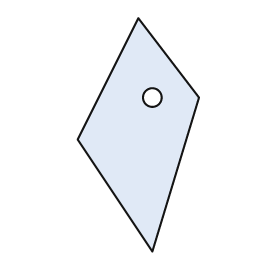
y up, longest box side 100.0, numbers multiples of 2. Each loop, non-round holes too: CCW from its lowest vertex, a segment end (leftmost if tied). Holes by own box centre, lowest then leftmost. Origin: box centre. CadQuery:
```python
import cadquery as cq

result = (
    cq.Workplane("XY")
    .moveTo(6.0, -50.0)
    .lineTo(26.0, 16.0)
    .lineTo(0.0, 50.0)
    .lineTo(-26.0, -2.0)
    .close()
    .moveTo(6.0, 16.0)
    .circle(4.0)
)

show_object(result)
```